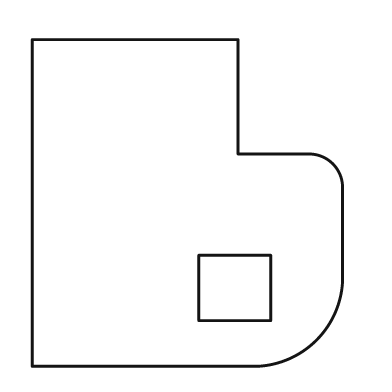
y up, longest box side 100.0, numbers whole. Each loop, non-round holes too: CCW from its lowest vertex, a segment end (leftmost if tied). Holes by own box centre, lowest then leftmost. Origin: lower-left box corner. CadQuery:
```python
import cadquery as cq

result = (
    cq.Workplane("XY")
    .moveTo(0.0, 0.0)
    .lineTo(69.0, 0.0)
    .threePointArc((87.0, 8.0), (95.0, 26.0))
    .lineTo(95.0, 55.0)
    .threePointArc((92.0, 62.0), (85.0, 65.0))
    .lineTo(63.0, 65.0)
    .lineTo(63.0, 100.0)
    .lineTo(0.0, 100.0)
    .close()
    .moveTo(51.0, 14.0)
    .lineTo(73.0, 14.0)
    .lineTo(73.0, 34.0)
    .lineTo(51.0, 34.0)
    .close()
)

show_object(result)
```